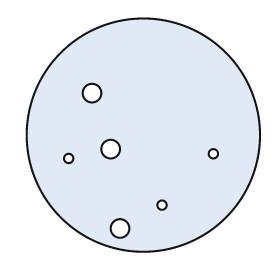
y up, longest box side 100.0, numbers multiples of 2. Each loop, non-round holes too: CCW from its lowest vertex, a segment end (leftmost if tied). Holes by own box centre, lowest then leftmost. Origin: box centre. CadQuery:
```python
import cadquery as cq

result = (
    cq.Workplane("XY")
    .moveTo(0.0, 0.0)
    .circle(50.0)
    .moveTo(-10.0, -40.0)
    .circle(4.0)
    .moveTo(8.0, -30.0)
    .circle(2.0)
    .moveTo(-32.0, -10.0)
    .circle(2.0)
    .moveTo(30.0, -8.0)
    .circle(2.0)
    .moveTo(-14.0, -6.0)
    .circle(4.0)
    .moveTo(-22.0, 18.0)
    .circle(4.0)
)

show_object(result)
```